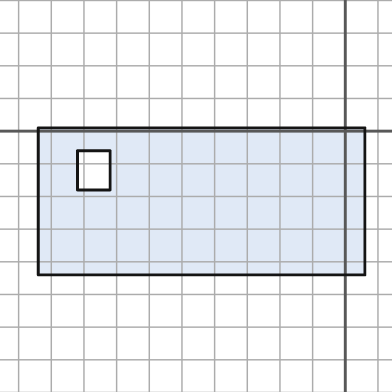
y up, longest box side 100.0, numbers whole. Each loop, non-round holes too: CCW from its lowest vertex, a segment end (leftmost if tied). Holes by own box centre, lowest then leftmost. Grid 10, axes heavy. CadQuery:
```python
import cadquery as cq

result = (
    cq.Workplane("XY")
    .moveTo(-94.0, -44.0)
    .lineTo(6.0, -44.0)
    .lineTo(6.0, 1.0)
    .lineTo(-94.0, 1.0)
    .close()
    .moveTo(-82.0, -18.0)
    .lineTo(-72.0, -18.0)
    .lineTo(-72.0, -6.0)
    .lineTo(-82.0, -6.0)
    .close()
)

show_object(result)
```